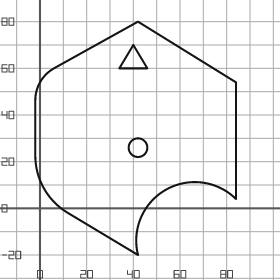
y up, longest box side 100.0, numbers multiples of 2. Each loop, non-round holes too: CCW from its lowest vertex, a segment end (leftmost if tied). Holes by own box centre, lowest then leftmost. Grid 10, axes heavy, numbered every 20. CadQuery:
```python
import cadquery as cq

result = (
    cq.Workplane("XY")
    .moveTo(42.0, -20.0)
    .threePointArc((54.0, 8.0), (84.0, 4.0))
    .lineTo(84.0, 54.0)
    .lineTo(42.0, 80.0)
    .lineTo(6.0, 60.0)
    .threePointArc((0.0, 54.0), (-2.0, 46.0))
    .lineTo(-2.0, 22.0)
    .threePointArc((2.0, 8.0), (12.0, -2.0))
    .close()
    .moveTo(42.0, 26.0)
    .circle(4.0)
    .moveTo(34.0, 60.0)
    .lineTo(46.0, 60.0)
    .lineTo(40.0, 70.0)
    .close()
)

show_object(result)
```